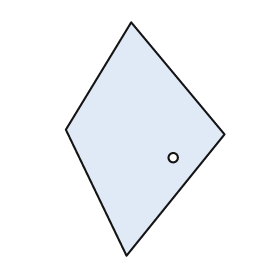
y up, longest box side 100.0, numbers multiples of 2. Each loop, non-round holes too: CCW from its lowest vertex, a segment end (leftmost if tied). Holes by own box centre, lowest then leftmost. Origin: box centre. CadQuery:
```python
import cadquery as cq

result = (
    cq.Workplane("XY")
    .moveTo(-8.0, -50.0)
    .lineTo(34.0, 2.0)
    .lineTo(-6.0, 50.0)
    .lineTo(-34.0, 4.0)
    .close()
    .moveTo(12.0, -8.0)
    .circle(2.0)
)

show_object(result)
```